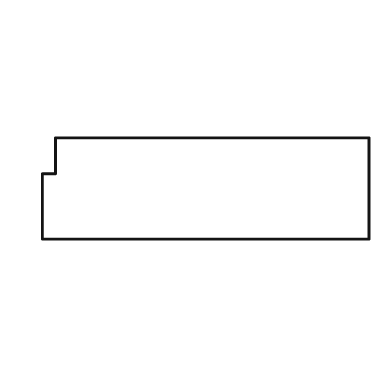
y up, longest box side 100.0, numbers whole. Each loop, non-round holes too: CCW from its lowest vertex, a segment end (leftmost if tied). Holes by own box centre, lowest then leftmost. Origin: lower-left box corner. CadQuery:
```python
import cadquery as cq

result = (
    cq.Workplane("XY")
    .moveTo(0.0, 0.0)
    .lineTo(100.0, 0.0)
    .lineTo(100.0, 31.0)
    .lineTo(4.0, 31.0)
    .lineTo(4.0, 20.0)
    .lineTo(0.0, 20.0)
    .close()
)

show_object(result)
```